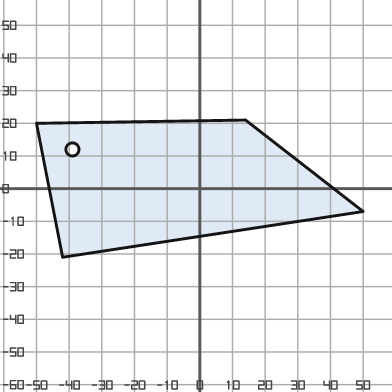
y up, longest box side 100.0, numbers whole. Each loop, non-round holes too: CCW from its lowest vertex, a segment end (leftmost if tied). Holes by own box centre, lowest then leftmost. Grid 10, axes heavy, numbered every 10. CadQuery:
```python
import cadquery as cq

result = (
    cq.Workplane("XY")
    .moveTo(-42.0, -21.0)
    .lineTo(50.0, -7.0)
    .lineTo(14.0, 21.0)
    .lineTo(-50.0, 20.0)
    .close()
    .moveTo(-39.0, 12.0)
    .circle(2.0)
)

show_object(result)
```